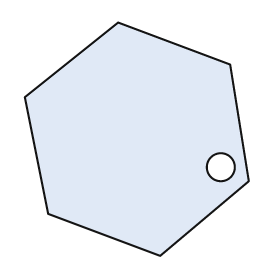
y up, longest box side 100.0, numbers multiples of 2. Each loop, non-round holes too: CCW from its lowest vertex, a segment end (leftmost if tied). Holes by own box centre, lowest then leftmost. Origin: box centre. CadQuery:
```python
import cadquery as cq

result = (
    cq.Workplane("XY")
    .moveTo(10.0, -50.0)
    .lineTo(48.0, -18.0)
    .lineTo(40.0, 32.0)
    .lineTo(-8.0, 50.0)
    .lineTo(-48.0, 18.0)
    .lineTo(-38.0, -32.0)
    .close()
    .moveTo(36.0, -12.0)
    .circle(6.0)
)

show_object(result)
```